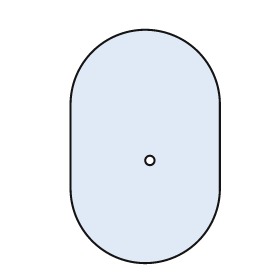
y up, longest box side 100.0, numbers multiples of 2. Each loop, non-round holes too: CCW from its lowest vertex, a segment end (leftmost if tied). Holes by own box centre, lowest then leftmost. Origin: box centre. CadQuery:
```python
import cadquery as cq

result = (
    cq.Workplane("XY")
    .moveTo(-32.0, -18.0)
    .threePointArc((0.0, -50.0), (32.0, -18.0))
    .lineTo(32.0, 18.0)
    .threePointArc((0.0, 50.0), (-32.0, 18.0))
    .close()
    .moveTo(2.0, -6.0)
    .circle(2.0)
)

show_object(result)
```